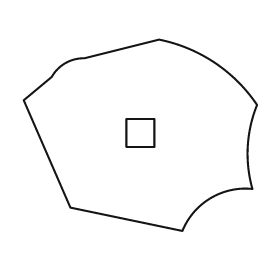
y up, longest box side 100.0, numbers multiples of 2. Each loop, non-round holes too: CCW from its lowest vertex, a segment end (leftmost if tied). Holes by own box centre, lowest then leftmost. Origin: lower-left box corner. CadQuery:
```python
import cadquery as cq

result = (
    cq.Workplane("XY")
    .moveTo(68.0, 0.0)
    .threePointArc((80.0, 14.0), (98.0, 18.0))
    .threePointArc((96.0, 36.0), (100.0, 54.0))
    .threePointArc((82.0, 72.0), (58.0, 82.0))
    .lineTo(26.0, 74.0)
    .threePointArc((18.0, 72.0), (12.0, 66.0))
    .lineTo(0.0, 56.0)
    .lineTo(20.0, 10.0)
    .close()
    .moveTo(44.0, 36.0)
    .lineTo(56.0, 36.0)
    .lineTo(56.0, 48.0)
    .lineTo(44.0, 48.0)
    .close()
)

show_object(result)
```